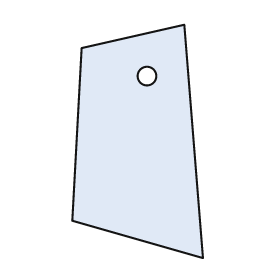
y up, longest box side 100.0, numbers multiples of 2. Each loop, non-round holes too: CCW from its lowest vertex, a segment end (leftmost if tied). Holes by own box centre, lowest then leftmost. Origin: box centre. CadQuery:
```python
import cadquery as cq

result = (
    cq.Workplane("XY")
    .moveTo(28.0, -50.0)
    .lineTo(20.0, 50.0)
    .lineTo(-24.0, 40.0)
    .lineTo(-28.0, -34.0)
    .close()
    .moveTo(4.0, 28.0)
    .circle(4.0)
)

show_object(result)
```